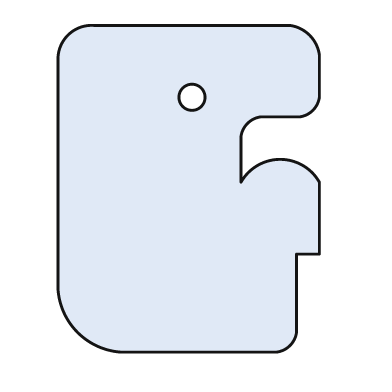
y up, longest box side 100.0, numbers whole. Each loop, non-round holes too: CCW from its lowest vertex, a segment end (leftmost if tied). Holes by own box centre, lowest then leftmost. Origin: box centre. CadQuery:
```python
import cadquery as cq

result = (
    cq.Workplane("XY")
    .moveTo(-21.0, -50.0)
    .lineTo(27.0, -50.0)
    .threePointArc((31.0, -48.0), (33.0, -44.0))
    .lineTo(33.0, -20.0)
    .lineTo(40.0, -20.0)
    .lineTo(40.0, 2.0)
    .threePointArc((28.0, 9.0), (16.0, 2.0))
    .lineTo(16.0, 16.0)
    .threePointArc((18.0, 20.0), (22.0, 22.0))
    .lineTo(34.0, 22.0)
    .threePointArc((38.0, 24.0), (40.0, 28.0))
    .lineTo(40.0, 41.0)
    .threePointArc((37.0, 47.0), (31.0, 50.0))
    .lineTo(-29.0, 50.0)
    .threePointArc((-37.0, 47.0), (-40.0, 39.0))
    .lineTo(-40.0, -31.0)
    .threePointArc((-34.0, -44.0), (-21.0, -50.0))
    .close()
    .moveTo(1.0, 28.0)
    .circle(4.0)
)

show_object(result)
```